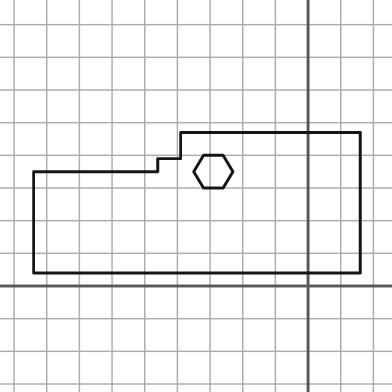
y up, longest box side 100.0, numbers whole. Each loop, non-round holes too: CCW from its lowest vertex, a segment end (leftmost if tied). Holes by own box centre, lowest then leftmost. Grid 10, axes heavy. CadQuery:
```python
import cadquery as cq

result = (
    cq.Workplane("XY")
    .moveTo(-84.0, 4.0)
    .lineTo(16.0, 4.0)
    .lineTo(16.0, 47.0)
    .lineTo(-39.0, 47.0)
    .lineTo(-39.0, 39.0)
    .lineTo(-46.0, 39.0)
    .lineTo(-46.0, 35.0)
    .lineTo(-84.0, 35.0)
    .close()
    .moveTo(-32.0, 30.0)
    .lineTo(-26.0, 30.0)
    .lineTo(-23.0, 35.0)
    .lineTo(-26.0, 40.0)
    .lineTo(-32.0, 40.0)
    .lineTo(-35.0, 35.0)
    .close()
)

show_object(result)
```